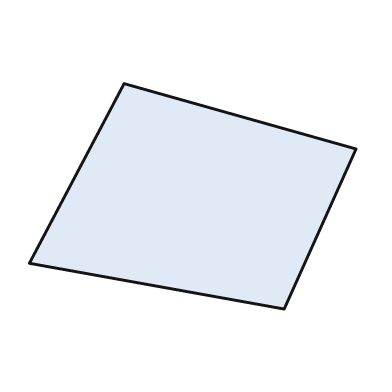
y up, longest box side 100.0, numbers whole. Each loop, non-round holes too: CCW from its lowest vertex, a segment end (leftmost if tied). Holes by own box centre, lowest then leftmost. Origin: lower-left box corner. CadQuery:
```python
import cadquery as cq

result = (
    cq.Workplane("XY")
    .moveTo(78.0, 0.0)
    .lineTo(100.0, 49.0)
    .lineTo(29.0, 69.0)
    .lineTo(0.0, 14.0)
    .close()
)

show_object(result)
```